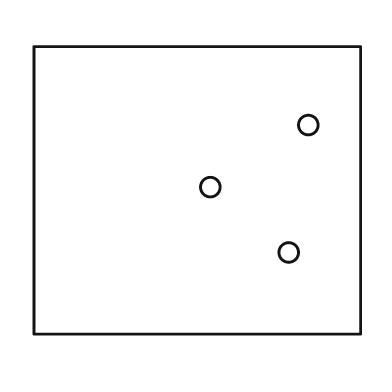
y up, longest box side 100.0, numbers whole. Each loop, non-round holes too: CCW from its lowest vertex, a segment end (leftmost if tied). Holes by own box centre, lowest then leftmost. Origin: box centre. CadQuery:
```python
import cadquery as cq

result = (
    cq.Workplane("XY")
    .moveTo(-50.0, -44.0)
    .lineTo(50.0, -44.0)
    .lineTo(50.0, 44.0)
    .lineTo(-50.0, 44.0)
    .close()
    .moveTo(28.0, -19.0)
    .circle(3.0)
    .moveTo(4.0, 1.0)
    .circle(3.0)
    .moveTo(34.0, 20.0)
    .circle(3.0)
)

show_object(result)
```